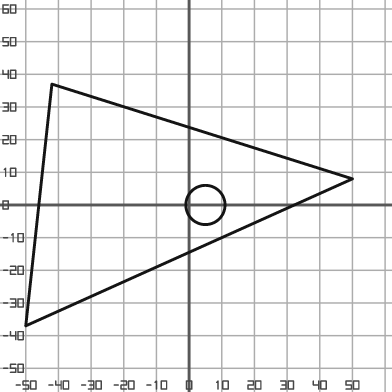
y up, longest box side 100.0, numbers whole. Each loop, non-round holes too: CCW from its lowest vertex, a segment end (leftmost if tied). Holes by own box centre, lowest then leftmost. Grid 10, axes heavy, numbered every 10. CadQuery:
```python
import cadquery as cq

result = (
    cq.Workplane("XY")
    .moveTo(-50.0, -37.0)
    .lineTo(50.0, 8.0)
    .lineTo(-42.0, 37.0)
    .close()
    .moveTo(5.0, 0.0)
    .circle(6.0)
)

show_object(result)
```